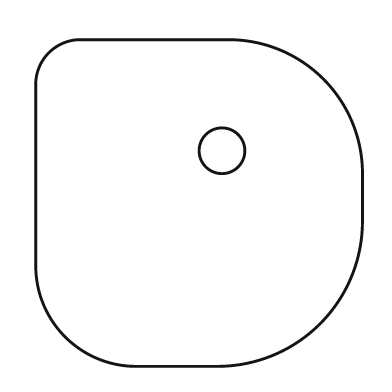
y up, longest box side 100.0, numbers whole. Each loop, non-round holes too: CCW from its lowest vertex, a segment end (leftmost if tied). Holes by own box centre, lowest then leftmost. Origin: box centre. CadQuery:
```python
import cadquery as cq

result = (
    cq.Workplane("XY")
    .moveTo(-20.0, -50.0)
    .lineTo(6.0, -50.0)
    .threePointArc((37.0, -37.0), (50.0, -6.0))
    .lineTo(50.0, 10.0)
    .threePointArc((38.0, 38.0), (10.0, 50.0))
    .lineTo(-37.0, 50.0)
    .threePointArc((-46.0, 46.0), (-50.0, 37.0))
    .lineTo(-50.0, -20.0)
    .threePointArc((-41.0, -41.0), (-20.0, -50.0))
    .close()
    .moveTo(7.0, 16.0)
    .circle(7.0)
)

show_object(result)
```